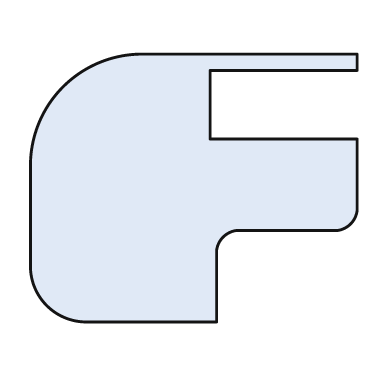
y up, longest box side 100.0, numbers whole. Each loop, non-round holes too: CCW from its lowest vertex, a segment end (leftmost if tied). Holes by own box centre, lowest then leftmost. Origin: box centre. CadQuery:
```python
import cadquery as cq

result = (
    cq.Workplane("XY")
    .moveTo(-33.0, -41.0)
    .lineTo(7.0, -41.0)
    .lineTo(7.0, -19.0)
    .threePointArc((9.0, -15.0), (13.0, -13.0))
    .lineTo(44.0, -13.0)
    .threePointArc((48.0, -11.0), (50.0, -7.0))
    .lineTo(50.0, 15.0)
    .lineTo(5.0, 15.0)
    .lineTo(5.0, 36.0)
    .lineTo(50.0, 36.0)
    .lineTo(50.0, 41.0)
    .lineTo(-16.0, 41.0)
    .threePointArc((-40.0, 31.0), (-50.0, 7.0))
    .lineTo(-50.0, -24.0)
    .threePointArc((-45.0, -36.0), (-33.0, -41.0))
    .close()
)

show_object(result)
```